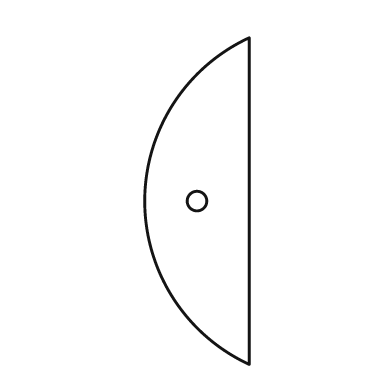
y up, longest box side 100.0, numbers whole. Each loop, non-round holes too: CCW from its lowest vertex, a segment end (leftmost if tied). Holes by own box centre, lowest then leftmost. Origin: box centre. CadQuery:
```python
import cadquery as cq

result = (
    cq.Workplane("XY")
    .moveTo(16.0, -50.0)
    .lineTo(16.0, 50.0)
    .threePointArc((-16.0, 0.0), (16.0, -50.0))
    .close()
    .moveTo(0.0, 0.0)
    .circle(3.0)
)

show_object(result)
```